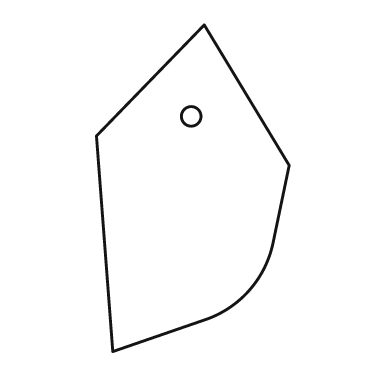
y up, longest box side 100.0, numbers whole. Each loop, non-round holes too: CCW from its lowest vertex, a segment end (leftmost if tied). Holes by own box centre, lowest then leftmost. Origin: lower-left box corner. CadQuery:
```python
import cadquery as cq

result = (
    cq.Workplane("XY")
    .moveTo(5.0, 0.0)
    .lineTo(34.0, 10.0)
    .threePointArc((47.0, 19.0), (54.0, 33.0))
    .lineTo(59.0, 57.0)
    .lineTo(33.0, 100.0)
    .lineTo(0.0, 66.0)
    .close()
    .moveTo(29.0, 72.0)
    .circle(3.0)
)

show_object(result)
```